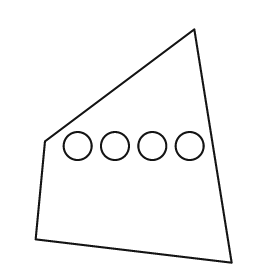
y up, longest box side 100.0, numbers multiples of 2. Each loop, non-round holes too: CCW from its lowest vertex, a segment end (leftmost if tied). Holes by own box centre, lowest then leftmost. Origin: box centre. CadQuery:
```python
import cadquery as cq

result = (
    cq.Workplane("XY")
    .moveTo(42.0, -50.0)
    .lineTo(26.0, 50.0)
    .lineTo(-38.0, 2.0)
    .lineTo(-42.0, -40.0)
    .close()
    .moveTo(-24.0, 0.0)
    .circle(6.0)
    .moveTo(-8.0, 0.0)
    .circle(6.0)
    .moveTo(8.0, 0.0)
    .circle(6.0)
    .moveTo(24.0, 0.0)
    .circle(6.0)
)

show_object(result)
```